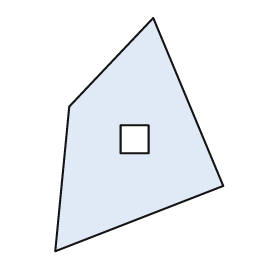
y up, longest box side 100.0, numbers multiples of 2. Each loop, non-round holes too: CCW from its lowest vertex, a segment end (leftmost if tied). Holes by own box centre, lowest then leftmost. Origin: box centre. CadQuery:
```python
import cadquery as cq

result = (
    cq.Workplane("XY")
    .moveTo(-36.0, -50.0)
    .lineTo(36.0, -22.0)
    .lineTo(6.0, 50.0)
    .lineTo(-30.0, 12.0)
    .close()
    .moveTo(-8.0, -8.0)
    .lineTo(4.0, -8.0)
    .lineTo(4.0, 4.0)
    .lineTo(-8.0, 4.0)
    .close()
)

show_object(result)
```